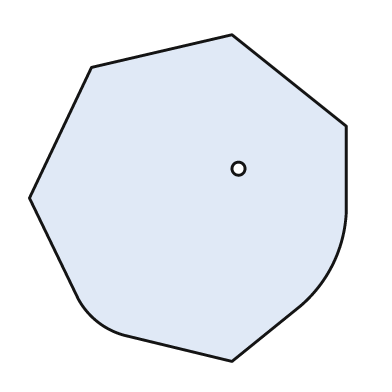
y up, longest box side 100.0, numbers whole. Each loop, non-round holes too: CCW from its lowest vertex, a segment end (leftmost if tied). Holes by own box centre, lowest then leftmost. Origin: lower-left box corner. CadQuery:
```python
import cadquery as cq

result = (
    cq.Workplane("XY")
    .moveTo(62.0, 0.0)
    .lineTo(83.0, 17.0)
    .threePointArc((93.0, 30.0), (97.0, 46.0))
    .lineTo(97.0, 72.0)
    .lineTo(62.0, 100.0)
    .lineTo(19.0, 90.0)
    .lineTo(0.0, 50.0)
    .lineTo(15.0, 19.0)
    .threePointArc((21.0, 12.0), (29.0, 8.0))
    .close()
    .moveTo(64.0, 59.0)
    .circle(2.0)
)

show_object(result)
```